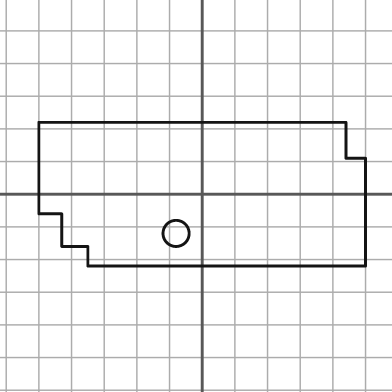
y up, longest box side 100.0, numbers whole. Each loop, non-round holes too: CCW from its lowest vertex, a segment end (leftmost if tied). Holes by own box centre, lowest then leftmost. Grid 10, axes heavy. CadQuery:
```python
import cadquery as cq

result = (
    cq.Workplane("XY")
    .moveTo(-35.0, -22.0)
    .lineTo(50.0, -22.0)
    .lineTo(50.0, 11.0)
    .lineTo(44.0, 11.0)
    .lineTo(44.0, 22.0)
    .lineTo(-50.0, 22.0)
    .lineTo(-50.0, -6.0)
    .lineTo(-43.0, -6.0)
    .lineTo(-43.0, -16.0)
    .lineTo(-35.0, -16.0)
    .close()
    .moveTo(-8.0, -12.0)
    .circle(4.0)
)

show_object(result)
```